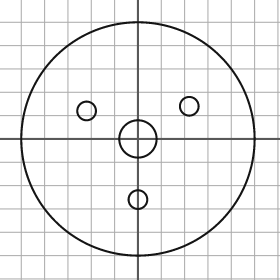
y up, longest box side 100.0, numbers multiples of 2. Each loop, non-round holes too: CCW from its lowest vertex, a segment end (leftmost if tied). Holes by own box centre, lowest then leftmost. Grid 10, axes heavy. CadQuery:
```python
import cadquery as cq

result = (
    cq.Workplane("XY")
    .moveTo(0.0, 0.0)
    .circle(50.0)
    .moveTo(0.0, -26.0)
    .circle(4.0)
    .moveTo(0.0, 0.0)
    .circle(8.0)
    .moveTo(-22.0, 12.0)
    .circle(4.0)
    .moveTo(22.0, 14.0)
    .circle(4.0)
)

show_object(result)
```